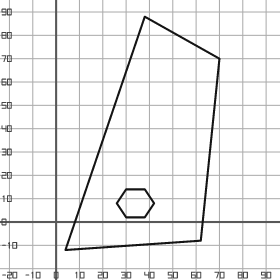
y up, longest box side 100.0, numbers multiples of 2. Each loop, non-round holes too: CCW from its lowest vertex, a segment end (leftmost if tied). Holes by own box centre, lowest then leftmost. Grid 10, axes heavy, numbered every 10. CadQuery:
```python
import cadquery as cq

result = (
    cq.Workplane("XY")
    .moveTo(4.0, -12.0)
    .lineTo(62.0, -8.0)
    .lineTo(70.0, 70.0)
    .lineTo(38.0, 88.0)
    .close()
    .moveTo(30.0, 2.0)
    .lineTo(38.0, 2.0)
    .lineTo(42.0, 8.0)
    .lineTo(38.0, 14.0)
    .lineTo(30.0, 14.0)
    .lineTo(26.0, 8.0)
    .close()
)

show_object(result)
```